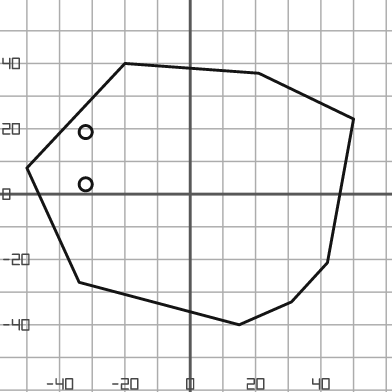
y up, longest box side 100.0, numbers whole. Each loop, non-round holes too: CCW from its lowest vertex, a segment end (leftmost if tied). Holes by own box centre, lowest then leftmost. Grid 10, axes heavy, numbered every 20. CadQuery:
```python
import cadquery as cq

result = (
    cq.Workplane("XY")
    .moveTo(15.0, -40.0)
    .lineTo(31.0, -33.0)
    .lineTo(42.0, -21.0)
    .lineTo(50.0, 23.0)
    .lineTo(21.0, 37.0)
    .lineTo(-20.0, 40.0)
    .lineTo(-50.0, 8.0)
    .lineTo(-34.0, -27.0)
    .close()
    .moveTo(-32.0, 3.0)
    .circle(2.0)
    .moveTo(-32.0, 19.0)
    .circle(2.0)
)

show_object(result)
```